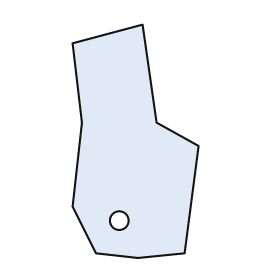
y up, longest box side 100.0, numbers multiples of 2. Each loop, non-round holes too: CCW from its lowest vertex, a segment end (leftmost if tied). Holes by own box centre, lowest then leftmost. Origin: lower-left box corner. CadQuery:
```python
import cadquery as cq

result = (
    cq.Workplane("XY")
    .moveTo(28.0, 0.0)
    .lineTo(48.0, 2.0)
    .lineTo(54.0, 48.0)
    .lineTo(36.0, 58.0)
    .lineTo(30.0, 100.0)
    .lineTo(0.0, 92.0)
    .lineTo(4.0, 58.0)
    .lineTo(0.0, 22.0)
    .lineTo(10.0, 2.0)
    .close()
    .moveTo(20.0, 16.0)
    .circle(4.0)
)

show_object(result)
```